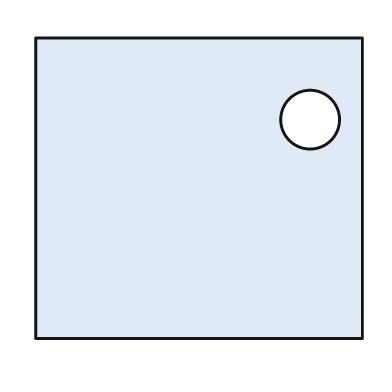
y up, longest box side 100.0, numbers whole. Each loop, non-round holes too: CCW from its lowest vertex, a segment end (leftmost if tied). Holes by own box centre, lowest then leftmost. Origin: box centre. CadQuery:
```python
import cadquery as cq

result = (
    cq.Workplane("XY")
    .moveTo(-50.0, -46.0)
    .lineTo(50.0, -46.0)
    .lineTo(50.0, 46.0)
    .lineTo(-50.0, 46.0)
    .close()
    .moveTo(34.0, 21.0)
    .circle(9.0)
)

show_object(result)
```